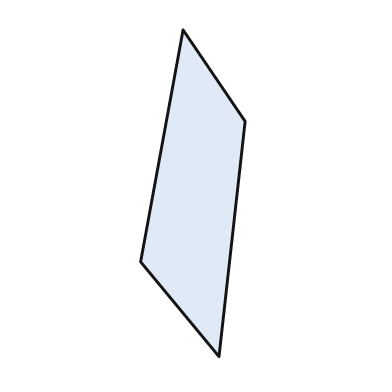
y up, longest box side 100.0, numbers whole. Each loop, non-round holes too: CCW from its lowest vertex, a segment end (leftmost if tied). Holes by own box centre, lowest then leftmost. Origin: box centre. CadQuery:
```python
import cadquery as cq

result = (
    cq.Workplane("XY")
    .moveTo(8.0, -50.0)
    .lineTo(16.0, 22.0)
    .lineTo(-3.0, 50.0)
    .lineTo(-16.0, -21.0)
    .close()
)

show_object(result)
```